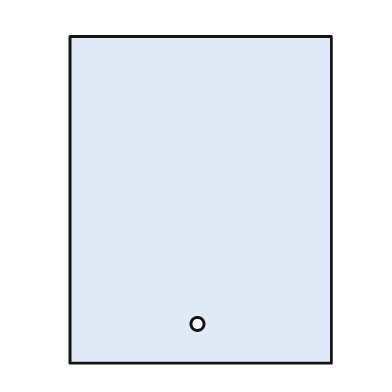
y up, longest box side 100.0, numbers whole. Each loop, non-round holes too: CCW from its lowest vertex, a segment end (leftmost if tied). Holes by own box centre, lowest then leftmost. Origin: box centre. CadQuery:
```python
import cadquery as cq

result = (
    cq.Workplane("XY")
    .moveTo(-40.0, -50.0)
    .lineTo(40.0, -50.0)
    .lineTo(40.0, 50.0)
    .lineTo(-40.0, 50.0)
    .close()
    .moveTo(-1.0, -38.0)
    .circle(2.0)
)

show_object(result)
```